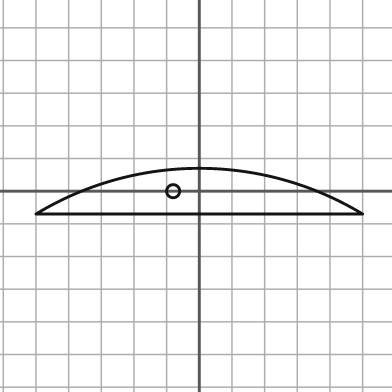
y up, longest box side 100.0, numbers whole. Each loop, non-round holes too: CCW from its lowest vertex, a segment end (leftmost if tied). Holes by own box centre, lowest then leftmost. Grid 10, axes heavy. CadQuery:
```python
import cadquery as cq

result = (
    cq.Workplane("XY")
    .moveTo(-50.0, -7.0)
    .lineTo(50.0, -7.0)
    .threePointArc((0.0, 7.0), (-50.0, -7.0))
    .close()
    .moveTo(-8.0, 0.0)
    .circle(2.0)
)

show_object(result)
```